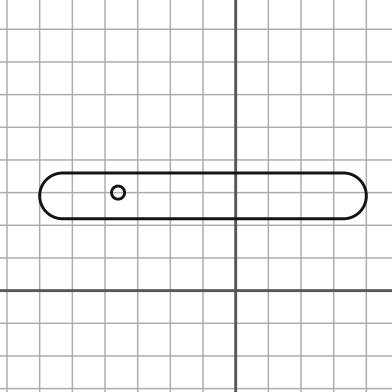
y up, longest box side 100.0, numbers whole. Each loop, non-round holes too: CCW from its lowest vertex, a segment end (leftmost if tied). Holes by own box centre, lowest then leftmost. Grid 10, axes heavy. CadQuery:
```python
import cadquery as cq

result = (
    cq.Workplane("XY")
    .moveTo(-53.0, 22.0)
    .lineTo(33.0, 22.0)
    .threePointArc((40.0, 29.0), (33.0, 36.0))
    .lineTo(-53.0, 36.0)
    .threePointArc((-60.0, 29.0), (-53.0, 22.0))
    .close()
    .moveTo(-36.0, 30.0)
    .circle(2.0)
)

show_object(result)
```